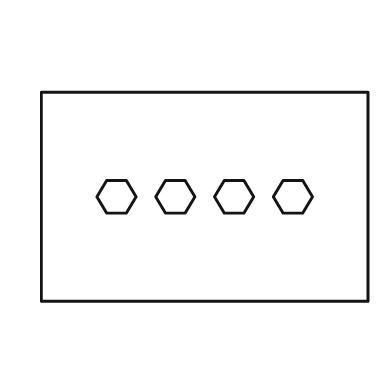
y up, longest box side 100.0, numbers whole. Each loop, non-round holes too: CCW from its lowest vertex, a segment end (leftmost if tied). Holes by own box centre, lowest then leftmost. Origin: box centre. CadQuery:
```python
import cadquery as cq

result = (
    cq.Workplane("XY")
    .moveTo(-50.0, -32.0)
    .lineTo(50.0, -32.0)
    .lineTo(50.0, 32.0)
    .lineTo(-50.0, 32.0)
    .close()
    .moveTo(-30.0, -5.0)
    .lineTo(-24.0, -5.0)
    .lineTo(-21.0, 0.0)
    .lineTo(-24.0, 5.0)
    .lineTo(-30.0, 5.0)
    .lineTo(-33.0, 0.0)
    .close()
    .moveTo(-12.0, -5.0)
    .lineTo(-6.0, -5.0)
    .lineTo(-3.0, 0.0)
    .lineTo(-6.0, 5.0)
    .lineTo(-12.0, 5.0)
    .lineTo(-15.0, 0.0)
    .close()
    .moveTo(6.0, -5.0)
    .lineTo(12.0, -5.0)
    .lineTo(15.0, 0.0)
    .lineTo(12.0, 5.0)
    .lineTo(6.0, 5.0)
    .lineTo(3.0, 0.0)
    .close()
    .moveTo(24.0, -5.0)
    .lineTo(30.0, -5.0)
    .lineTo(33.0, 0.0)
    .lineTo(30.0, 5.0)
    .lineTo(24.0, 5.0)
    .lineTo(21.0, 0.0)
    .close()
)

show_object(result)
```